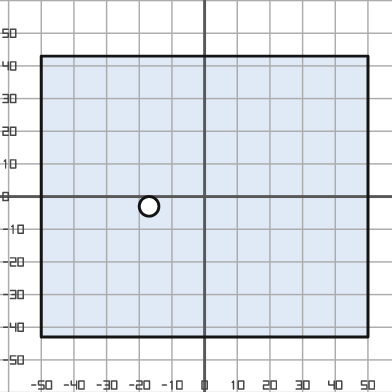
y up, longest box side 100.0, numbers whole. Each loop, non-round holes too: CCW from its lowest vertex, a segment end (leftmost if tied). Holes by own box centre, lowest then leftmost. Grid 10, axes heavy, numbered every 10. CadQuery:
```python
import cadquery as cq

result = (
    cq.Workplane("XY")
    .moveTo(-50.0, -43.0)
    .lineTo(50.0, -43.0)
    .lineTo(50.0, 43.0)
    .lineTo(-50.0, 43.0)
    .close()
    .moveTo(-17.0, -3.0)
    .circle(3.0)
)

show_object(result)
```